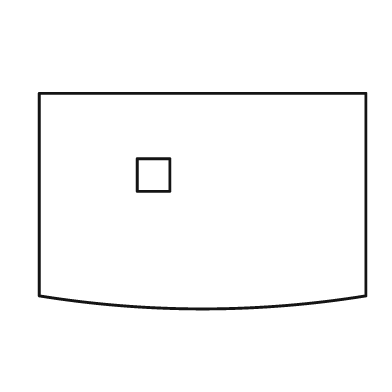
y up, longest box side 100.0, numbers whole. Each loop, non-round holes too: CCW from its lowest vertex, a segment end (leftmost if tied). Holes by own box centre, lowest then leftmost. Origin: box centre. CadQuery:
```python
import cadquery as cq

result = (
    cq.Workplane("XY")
    .moveTo(-50.0, -29.0)
    .threePointArc((0.0, -33.0), (50.0, -29.0))
    .lineTo(50.0, 33.0)
    .lineTo(-50.0, 33.0)
    .close()
    .moveTo(-20.0, 3.0)
    .lineTo(-10.0, 3.0)
    .lineTo(-10.0, 13.0)
    .lineTo(-20.0, 13.0)
    .close()
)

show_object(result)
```